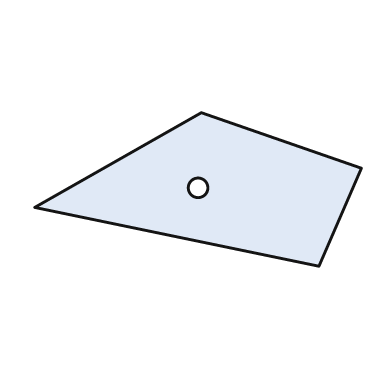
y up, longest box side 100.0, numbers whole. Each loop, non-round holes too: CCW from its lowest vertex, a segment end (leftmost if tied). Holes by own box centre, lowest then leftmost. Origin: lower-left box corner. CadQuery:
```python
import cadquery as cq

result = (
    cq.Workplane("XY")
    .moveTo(87.0, 0.0)
    .lineTo(100.0, 30.0)
    .lineTo(51.0, 47.0)
    .lineTo(0.0, 18.0)
    .close()
    .moveTo(50.0, 24.0)
    .circle(3.0)
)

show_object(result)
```